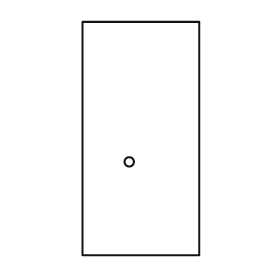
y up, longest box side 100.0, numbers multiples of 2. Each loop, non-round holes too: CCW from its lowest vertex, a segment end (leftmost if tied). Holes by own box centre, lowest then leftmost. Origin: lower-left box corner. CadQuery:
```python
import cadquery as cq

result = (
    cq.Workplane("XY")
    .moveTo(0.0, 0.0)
    .lineTo(50.0, 0.0)
    .lineTo(50.0, 100.0)
    .lineTo(0.0, 100.0)
    .close()
    .moveTo(20.0, 40.0)
    .circle(2.0)
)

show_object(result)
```